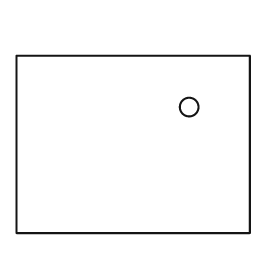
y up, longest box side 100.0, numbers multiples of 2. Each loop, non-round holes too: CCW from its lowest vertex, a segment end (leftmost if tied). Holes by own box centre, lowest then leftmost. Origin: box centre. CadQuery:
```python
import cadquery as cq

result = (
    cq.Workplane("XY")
    .moveTo(-50.0, -38.0)
    .lineTo(50.0, -38.0)
    .lineTo(50.0, 38.0)
    .lineTo(-50.0, 38.0)
    .close()
    .moveTo(24.0, 16.0)
    .circle(4.0)
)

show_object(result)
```